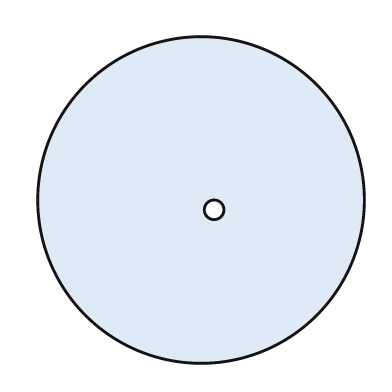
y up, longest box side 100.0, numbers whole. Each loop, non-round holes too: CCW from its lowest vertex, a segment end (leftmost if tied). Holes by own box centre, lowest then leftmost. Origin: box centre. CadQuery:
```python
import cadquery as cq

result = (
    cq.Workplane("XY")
    .moveTo(0.0, 0.0)
    .circle(50.0)
    .moveTo(4.0, -3.0)
    .circle(3.0)
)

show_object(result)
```